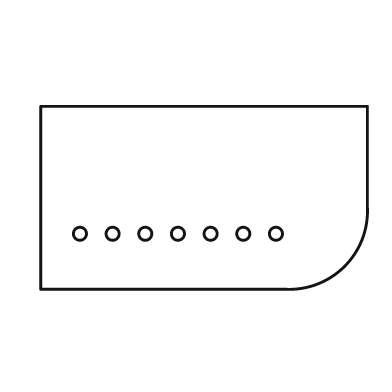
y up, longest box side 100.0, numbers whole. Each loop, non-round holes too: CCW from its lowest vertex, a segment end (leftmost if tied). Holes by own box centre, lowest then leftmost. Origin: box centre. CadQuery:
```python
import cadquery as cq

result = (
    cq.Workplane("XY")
    .moveTo(-50.0, -28.0)
    .lineTo(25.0, -28.0)
    .threePointArc((43.0, -21.0), (50.0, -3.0))
    .lineTo(50.0, 28.0)
    .lineTo(-50.0, 28.0)
    .close()
    .moveTo(-38.0, -11.0)
    .circle(2.0)
    .moveTo(-28.0, -11.0)
    .circle(2.0)
    .moveTo(-18.0, -11.0)
    .circle(2.0)
    .moveTo(-8.0, -11.0)
    .circle(2.0)
    .moveTo(2.0, -11.0)
    .circle(2.0)
    .moveTo(12.0, -11.0)
    .circle(2.0)
    .moveTo(22.0, -11.0)
    .circle(2.0)
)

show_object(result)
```